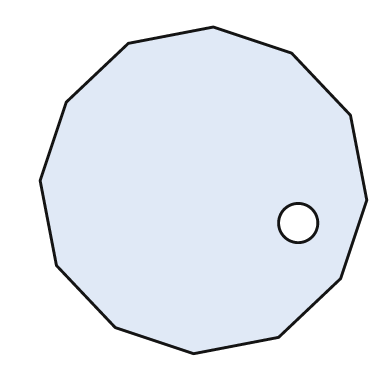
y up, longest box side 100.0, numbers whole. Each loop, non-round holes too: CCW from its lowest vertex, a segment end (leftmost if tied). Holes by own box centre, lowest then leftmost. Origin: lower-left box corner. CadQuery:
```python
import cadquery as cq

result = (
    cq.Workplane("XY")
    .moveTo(47.0, 0.0)
    .lineTo(73.0, 5.0)
    .lineTo(92.0, 23.0)
    .lineTo(100.0, 47.0)
    .lineTo(95.0, 73.0)
    .lineTo(77.0, 92.0)
    .lineTo(53.0, 100.0)
    .lineTo(27.0, 95.0)
    .lineTo(8.0, 77.0)
    .lineTo(0.0, 53.0)
    .lineTo(5.0, 27.0)
    .lineTo(23.0, 8.0)
    .close()
    .moveTo(79.0, 40.0)
    .circle(6.0)
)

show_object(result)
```